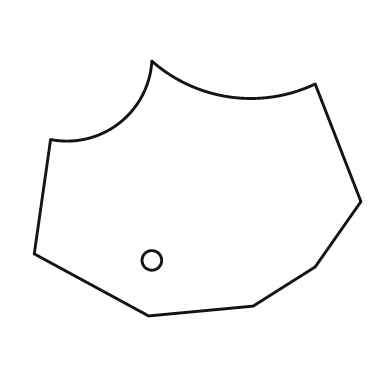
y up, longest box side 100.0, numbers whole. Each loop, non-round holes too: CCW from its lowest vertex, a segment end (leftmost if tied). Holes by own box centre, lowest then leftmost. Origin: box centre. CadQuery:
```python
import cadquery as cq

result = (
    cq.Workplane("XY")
    .moveTo(-15.0, -39.0)
    .lineTo(17.0, -36.0)
    .lineTo(36.0, -24.0)
    .lineTo(50.0, -4.0)
    .lineTo(36.0, 32.0)
    .threePointArc((10.0, 28.0), (-14.0, 39.0))
    .threePointArc((-24.0, 20.0), (-45.0, 15.0))
    .lineTo(-50.0, -20.0)
    .close()
    .moveTo(-14.0, -22.0)
    .circle(3.0)
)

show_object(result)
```